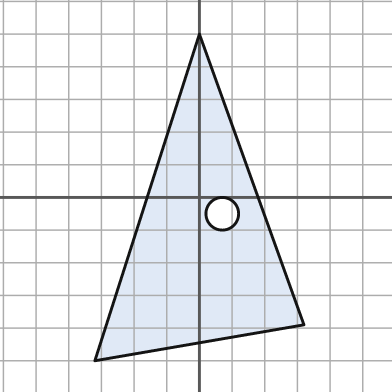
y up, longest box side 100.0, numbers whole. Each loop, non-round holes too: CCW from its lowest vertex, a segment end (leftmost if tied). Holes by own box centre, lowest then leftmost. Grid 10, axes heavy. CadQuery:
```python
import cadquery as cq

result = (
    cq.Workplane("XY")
    .moveTo(-32.0, -50.0)
    .lineTo(32.0, -39.0)
    .lineTo(0.0, 50.0)
    .close()
    .moveTo(7.0, -5.0)
    .circle(5.0)
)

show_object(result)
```